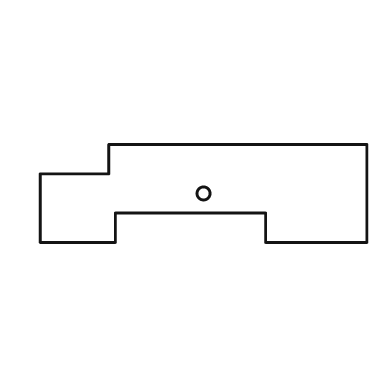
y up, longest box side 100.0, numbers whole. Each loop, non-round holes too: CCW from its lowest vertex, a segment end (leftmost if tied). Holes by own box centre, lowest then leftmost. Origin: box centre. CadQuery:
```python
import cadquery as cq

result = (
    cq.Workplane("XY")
    .moveTo(-50.0, -15.0)
    .lineTo(-27.0, -15.0)
    .lineTo(-27.0, -6.0)
    .lineTo(19.0, -6.0)
    .lineTo(19.0, -15.0)
    .lineTo(50.0, -15.0)
    .lineTo(50.0, 15.0)
    .lineTo(-29.0, 15.0)
    .lineTo(-29.0, 6.0)
    .lineTo(-50.0, 6.0)
    .close()
    .moveTo(0.0, 0.0)
    .circle(2.0)
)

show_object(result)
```